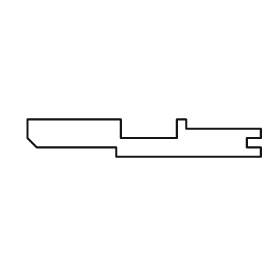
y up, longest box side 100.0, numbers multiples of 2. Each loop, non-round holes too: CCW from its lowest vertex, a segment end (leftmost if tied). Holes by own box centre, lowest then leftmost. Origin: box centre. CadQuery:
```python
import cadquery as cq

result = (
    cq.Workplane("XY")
    .moveTo(-12.0, -8.0)
    .lineTo(50.0, -8.0)
    .lineTo(50.0, -4.0)
    .lineTo(44.0, -4.0)
    .lineTo(44.0, 0.0)
    .lineTo(50.0, 0.0)
    .lineTo(50.0, 4.0)
    .lineTo(18.0, 4.0)
    .lineTo(18.0, 8.0)
    .lineTo(14.0, 8.0)
    .lineTo(14.0, 0.0)
    .lineTo(-10.0, 0.0)
    .lineTo(-10.0, 8.0)
    .lineTo(-50.0, 8.0)
    .lineTo(-50.0, 0.0)
    .lineTo(-46.0, -4.0)
    .lineTo(-12.0, -4.0)
    .close()
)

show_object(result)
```